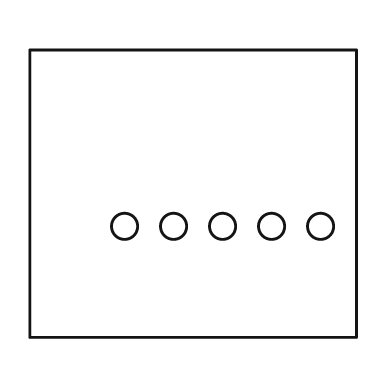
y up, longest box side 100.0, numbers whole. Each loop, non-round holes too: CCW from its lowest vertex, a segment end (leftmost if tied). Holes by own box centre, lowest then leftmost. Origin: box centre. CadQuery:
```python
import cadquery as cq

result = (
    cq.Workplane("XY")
    .moveTo(-50.0, -44.0)
    .lineTo(50.0, -44.0)
    .lineTo(50.0, 44.0)
    .lineTo(-50.0, 44.0)
    .close()
    .moveTo(-21.0, -10.0)
    .circle(4.0)
    .moveTo(-6.0, -10.0)
    .circle(4.0)
    .moveTo(9.0, -10.0)
    .circle(4.0)
    .moveTo(24.0, -10.0)
    .circle(4.0)
    .moveTo(39.0, -10.0)
    .circle(4.0)
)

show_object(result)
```